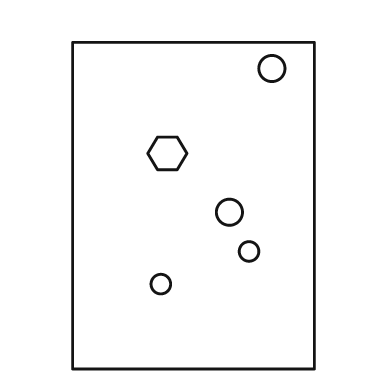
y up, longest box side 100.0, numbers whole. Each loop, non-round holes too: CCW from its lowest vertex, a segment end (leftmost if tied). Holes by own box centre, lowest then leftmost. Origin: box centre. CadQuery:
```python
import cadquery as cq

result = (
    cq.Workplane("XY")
    .moveTo(-37.0, -50.0)
    .lineTo(37.0, -50.0)
    .lineTo(37.0, 50.0)
    .lineTo(-37.0, 50.0)
    .close()
    .moveTo(-10.0, -24.0)
    .circle(3.0)
    .moveTo(17.0, -14.0)
    .circle(3.0)
    .moveTo(11.0, -2.0)
    .circle(4.0)
    .moveTo(-11.0, 11.0)
    .lineTo(-5.0, 11.0)
    .lineTo(-2.0, 16.0)
    .lineTo(-5.0, 21.0)
    .lineTo(-11.0, 21.0)
    .lineTo(-14.0, 16.0)
    .close()
    .moveTo(24.0, 42.0)
    .circle(4.0)
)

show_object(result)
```